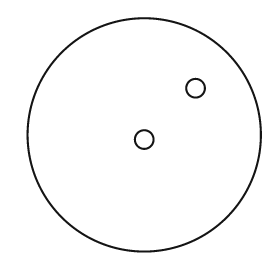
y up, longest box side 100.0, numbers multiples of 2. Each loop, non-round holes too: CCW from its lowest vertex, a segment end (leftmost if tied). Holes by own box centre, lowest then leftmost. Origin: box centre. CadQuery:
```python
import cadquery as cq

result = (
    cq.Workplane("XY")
    .moveTo(0.0, 0.0)
    .circle(50.0)
    .moveTo(0.0, -2.0)
    .circle(4.0)
    .moveTo(22.0, 20.0)
    .circle(4.0)
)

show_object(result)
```